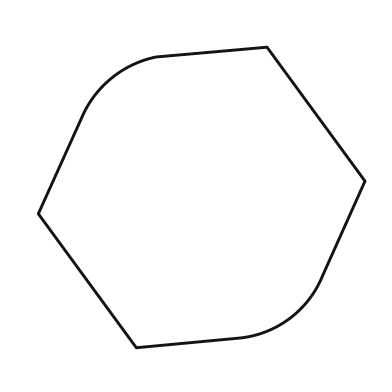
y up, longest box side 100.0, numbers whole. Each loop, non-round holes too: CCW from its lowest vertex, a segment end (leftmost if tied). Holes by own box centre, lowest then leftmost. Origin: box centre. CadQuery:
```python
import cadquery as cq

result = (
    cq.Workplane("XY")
    .moveTo(-20.0, -46.0)
    .lineTo(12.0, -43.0)
    .threePointArc((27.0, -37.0), (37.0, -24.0))
    .lineTo(50.0, 5.0)
    .lineTo(20.0, 46.0)
    .lineTo(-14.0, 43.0)
    .threePointArc((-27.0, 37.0), (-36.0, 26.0))
    .lineTo(-50.0, -5.0)
    .close()
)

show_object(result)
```